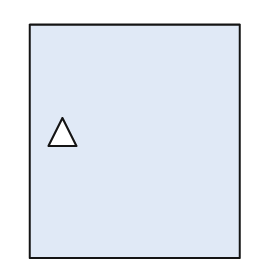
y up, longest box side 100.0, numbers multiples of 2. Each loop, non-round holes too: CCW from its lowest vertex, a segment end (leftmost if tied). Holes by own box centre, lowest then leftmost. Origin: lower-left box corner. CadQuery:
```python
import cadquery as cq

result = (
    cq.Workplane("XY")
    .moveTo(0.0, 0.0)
    .lineTo(90.0, 0.0)
    .lineTo(90.0, 100.0)
    .lineTo(0.0, 100.0)
    .close()
    .moveTo(8.0, 48.0)
    .lineTo(20.0, 48.0)
    .lineTo(14.0, 60.0)
    .close()
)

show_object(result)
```